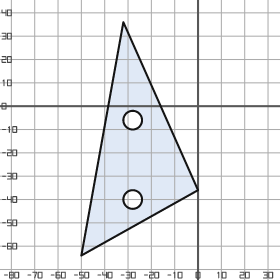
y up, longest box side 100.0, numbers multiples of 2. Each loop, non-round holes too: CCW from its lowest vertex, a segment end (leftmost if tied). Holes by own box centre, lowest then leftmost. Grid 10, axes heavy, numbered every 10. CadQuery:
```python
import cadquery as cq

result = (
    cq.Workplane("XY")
    .moveTo(-50.0, -64.0)
    .lineTo(0.0, -36.0)
    .lineTo(-32.0, 36.0)
    .close()
    .moveTo(-28.0, -40.0)
    .circle(4.0)
    .moveTo(-28.0, -6.0)
    .circle(4.0)
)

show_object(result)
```